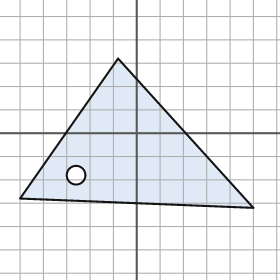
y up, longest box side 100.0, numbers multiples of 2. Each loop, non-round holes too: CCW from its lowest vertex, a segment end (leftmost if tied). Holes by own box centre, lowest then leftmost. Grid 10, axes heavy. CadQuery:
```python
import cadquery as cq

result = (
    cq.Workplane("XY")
    .moveTo(50.0, -32.0)
    .lineTo(-8.0, 32.0)
    .lineTo(-50.0, -28.0)
    .close()
    .moveTo(-26.0, -18.0)
    .circle(4.0)
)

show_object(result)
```